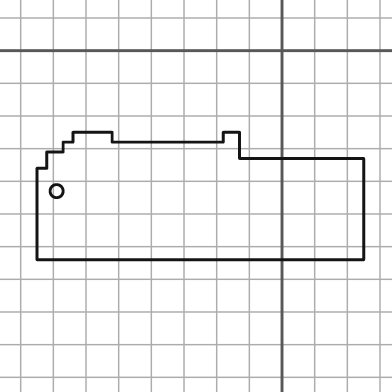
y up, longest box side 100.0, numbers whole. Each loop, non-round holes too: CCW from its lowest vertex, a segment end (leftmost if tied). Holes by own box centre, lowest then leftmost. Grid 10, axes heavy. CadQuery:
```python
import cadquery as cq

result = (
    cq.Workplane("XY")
    .moveTo(-75.0, -64.0)
    .lineTo(25.0, -64.0)
    .lineTo(25.0, -33.0)
    .lineTo(-13.0, -33.0)
    .lineTo(-13.0, -25.0)
    .lineTo(-18.0, -25.0)
    .lineTo(-18.0, -28.0)
    .lineTo(-52.0, -28.0)
    .lineTo(-52.0, -25.0)
    .lineTo(-64.0, -25.0)
    .lineTo(-64.0, -28.0)
    .lineTo(-67.0, -28.0)
    .lineTo(-67.0, -31.0)
    .lineTo(-72.0, -31.0)
    .lineTo(-72.0, -36.0)
    .lineTo(-75.0, -36.0)
    .close()
    .moveTo(-69.0, -43.0)
    .circle(2.0)
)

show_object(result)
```